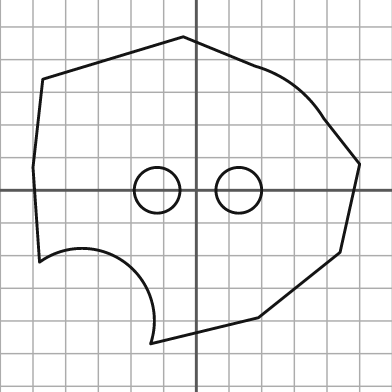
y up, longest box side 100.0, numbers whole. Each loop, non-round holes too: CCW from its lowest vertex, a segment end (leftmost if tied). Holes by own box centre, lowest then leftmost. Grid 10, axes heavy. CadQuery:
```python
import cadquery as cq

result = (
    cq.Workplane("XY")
    .moveTo(-14.0, -47.0)
    .lineTo(19.0, -39.0)
    .lineTo(44.0, -19.0)
    .lineTo(50.0, 8.0)
    .lineTo(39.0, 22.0)
    .threePointArc((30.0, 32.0), (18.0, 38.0))
    .lineTo(-4.0, 47.0)
    .lineTo(-47.0, 34.0)
    .lineTo(-50.0, 7.0)
    .lineTo(-48.0, -22.0)
    .threePointArc((-22.0, -22.0), (-14.0, -47.0))
    .close()
    .moveTo(-12.0, 0.0)
    .circle(7.0)
    .moveTo(13.0, 0.0)
    .circle(7.0)
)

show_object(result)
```